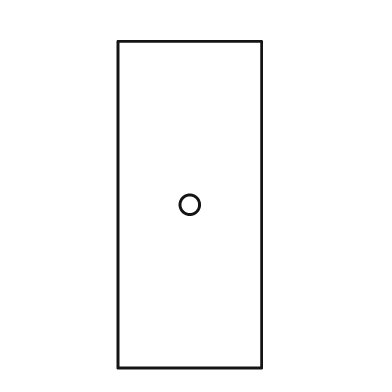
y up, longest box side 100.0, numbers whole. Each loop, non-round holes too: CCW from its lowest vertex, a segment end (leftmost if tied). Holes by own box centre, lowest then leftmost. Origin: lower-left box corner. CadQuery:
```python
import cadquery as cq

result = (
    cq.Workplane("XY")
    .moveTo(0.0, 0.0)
    .lineTo(44.0, 0.0)
    .lineTo(44.0, 100.0)
    .lineTo(0.0, 100.0)
    .close()
    .moveTo(22.0, 50.0)
    .circle(3.0)
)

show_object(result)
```